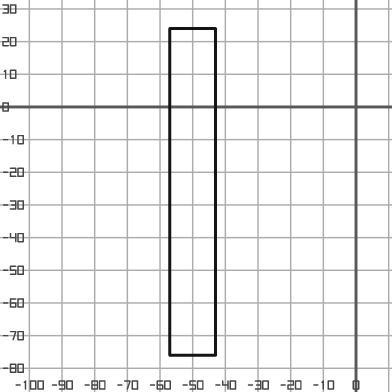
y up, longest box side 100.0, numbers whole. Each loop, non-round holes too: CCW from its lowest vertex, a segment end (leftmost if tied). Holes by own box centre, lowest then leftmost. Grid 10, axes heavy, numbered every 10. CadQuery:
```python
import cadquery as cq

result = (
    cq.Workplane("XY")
    .moveTo(-57.0, -76.0)
    .lineTo(-43.0, -76.0)
    .lineTo(-43.0, 24.0)
    .lineTo(-57.0, 24.0)
    .close()
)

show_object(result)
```